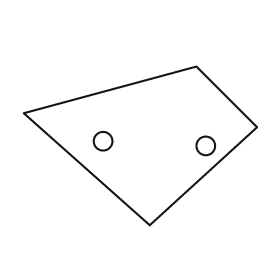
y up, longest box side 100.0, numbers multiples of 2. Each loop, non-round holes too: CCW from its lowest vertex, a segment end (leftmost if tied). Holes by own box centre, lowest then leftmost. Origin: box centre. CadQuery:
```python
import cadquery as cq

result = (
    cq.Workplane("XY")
    .moveTo(4.0, -34.0)
    .lineTo(50.0, 8.0)
    .lineTo(24.0, 34.0)
    .lineTo(-50.0, 14.0)
    .close()
    .moveTo(28.0, 0.0)
    .circle(4.0)
    .moveTo(-16.0, 2.0)
    .circle(4.0)
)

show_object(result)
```